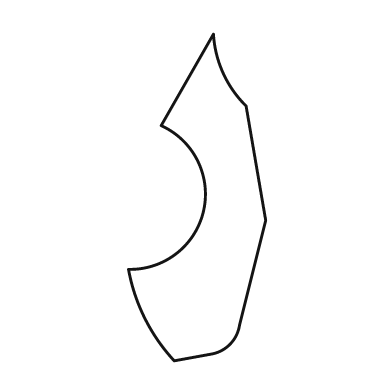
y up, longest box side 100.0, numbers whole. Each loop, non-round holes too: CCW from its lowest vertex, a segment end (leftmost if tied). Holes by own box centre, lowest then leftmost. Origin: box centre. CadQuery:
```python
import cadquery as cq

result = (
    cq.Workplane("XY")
    .moveTo(-7.0, -50.0)
    .lineTo(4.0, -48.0)
    .threePointArc((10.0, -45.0), (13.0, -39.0))
    .lineTo(21.0, -7.0)
    .lineTo(15.0, 28.0)
    .threePointArc((8.0, 38.0), (5.0, 50.0))
    .lineTo(-11.0, 22.0)
    .threePointArc((2.0, -4.0), (-21.0, -22.0))
    .threePointArc((-16.0, -37.0), (-7.0, -50.0))
    .close()
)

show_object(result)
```